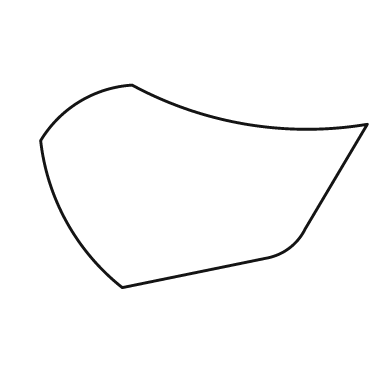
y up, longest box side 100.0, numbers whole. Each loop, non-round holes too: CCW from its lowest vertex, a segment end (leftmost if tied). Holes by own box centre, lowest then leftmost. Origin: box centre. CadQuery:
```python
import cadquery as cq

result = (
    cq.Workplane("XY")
    .moveTo(-25.0, -31.0)
    .lineTo(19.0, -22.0)
    .threePointArc((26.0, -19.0), (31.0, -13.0))
    .lineTo(50.0, 19.0)
    .threePointArc((13.0, 19.0), (-22.0, 31.0))
    .threePointArc((-38.0, 26.0), (-50.0, 14.0))
    .threePointArc((-42.0, -11.0), (-25.0, -31.0))
    .close()
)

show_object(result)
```